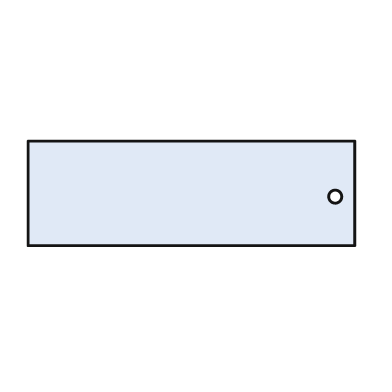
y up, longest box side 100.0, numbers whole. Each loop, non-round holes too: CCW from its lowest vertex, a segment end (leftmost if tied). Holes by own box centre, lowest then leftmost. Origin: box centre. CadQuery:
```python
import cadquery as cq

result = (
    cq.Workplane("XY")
    .moveTo(-50.0, -16.0)
    .lineTo(50.0, -16.0)
    .lineTo(50.0, 16.0)
    .lineTo(-50.0, 16.0)
    .close()
    .moveTo(44.0, -1.0)
    .circle(2.0)
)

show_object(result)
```